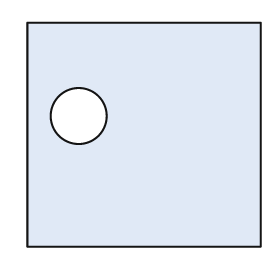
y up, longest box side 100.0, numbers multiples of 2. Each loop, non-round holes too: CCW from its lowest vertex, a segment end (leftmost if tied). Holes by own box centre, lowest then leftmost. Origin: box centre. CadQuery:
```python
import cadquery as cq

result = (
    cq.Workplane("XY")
    .moveTo(-50.0, -48.0)
    .lineTo(50.0, -48.0)
    .lineTo(50.0, 48.0)
    .lineTo(-50.0, 48.0)
    .close()
    .moveTo(-28.0, 8.0)
    .circle(12.0)
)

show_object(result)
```